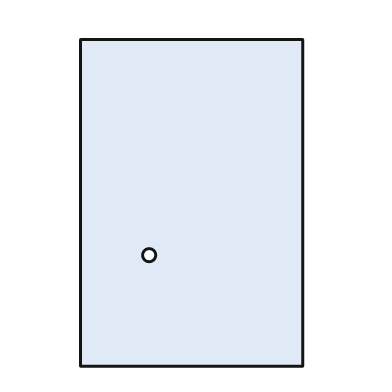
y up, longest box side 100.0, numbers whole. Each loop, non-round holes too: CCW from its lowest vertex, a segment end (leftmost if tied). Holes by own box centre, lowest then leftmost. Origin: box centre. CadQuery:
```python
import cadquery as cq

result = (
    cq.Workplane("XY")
    .moveTo(-34.0, -50.0)
    .lineTo(34.0, -50.0)
    .lineTo(34.0, 50.0)
    .lineTo(-34.0, 50.0)
    .close()
    .moveTo(-13.0, -16.0)
    .circle(2.0)
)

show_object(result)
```